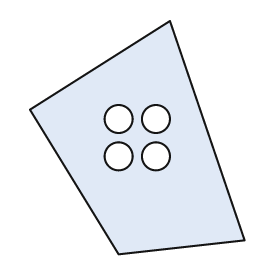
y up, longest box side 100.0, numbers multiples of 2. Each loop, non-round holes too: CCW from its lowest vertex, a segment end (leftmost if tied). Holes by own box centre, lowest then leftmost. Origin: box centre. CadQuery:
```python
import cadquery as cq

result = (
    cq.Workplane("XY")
    .moveTo(-8.0, -50.0)
    .lineTo(46.0, -44.0)
    .lineTo(14.0, 50.0)
    .lineTo(-46.0, 12.0)
    .close()
    .moveTo(-8.0, -8.0)
    .circle(6.0)
    .moveTo(8.0, -8.0)
    .circle(6.0)
    .moveTo(-8.0, 8.0)
    .circle(6.0)
    .moveTo(8.0, 8.0)
    .circle(6.0)
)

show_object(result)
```